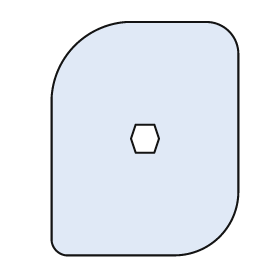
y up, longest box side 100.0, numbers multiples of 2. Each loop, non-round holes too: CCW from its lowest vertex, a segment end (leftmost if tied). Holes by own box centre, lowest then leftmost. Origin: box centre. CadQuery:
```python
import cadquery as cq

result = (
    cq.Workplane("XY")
    .moveTo(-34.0, -50.0)
    .lineTo(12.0, -50.0)
    .threePointArc((32.0, -42.0), (40.0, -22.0))
    .lineTo(40.0, 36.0)
    .threePointArc((36.0, 46.0), (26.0, 50.0))
    .lineTo(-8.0, 50.0)
    .threePointArc((-30.0, 40.0), (-40.0, 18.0))
    .lineTo(-40.0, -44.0)
    .threePointArc((-38.0, -48.0), (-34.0, -50.0))
    .close()
    .moveTo(-4.0, -6.0)
    .lineTo(4.0, -6.0)
    .lineTo(6.0, 0.0)
    .lineTo(4.0, 6.0)
    .lineTo(-4.0, 6.0)
    .lineTo(-6.0, 0.0)
    .close()
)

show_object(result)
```